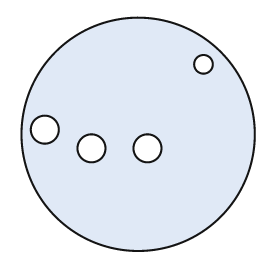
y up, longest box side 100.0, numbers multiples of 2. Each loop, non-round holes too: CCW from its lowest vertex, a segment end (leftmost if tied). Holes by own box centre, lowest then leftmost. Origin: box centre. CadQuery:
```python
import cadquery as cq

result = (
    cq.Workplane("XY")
    .moveTo(0.0, 0.0)
    .circle(50.0)
    .moveTo(-20.0, -6.0)
    .circle(6.0)
    .moveTo(4.0, -6.0)
    .circle(6.0)
    .moveTo(-40.0, 2.0)
    .circle(6.0)
    .moveTo(28.0, 30.0)
    .circle(4.0)
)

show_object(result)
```